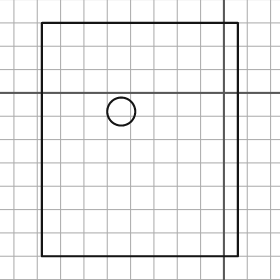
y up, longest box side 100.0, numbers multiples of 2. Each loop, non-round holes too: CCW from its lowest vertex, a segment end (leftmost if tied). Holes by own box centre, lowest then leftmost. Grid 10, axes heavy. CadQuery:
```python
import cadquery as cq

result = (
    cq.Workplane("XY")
    .moveTo(-78.0, -70.0)
    .lineTo(6.0, -70.0)
    .lineTo(6.0, 30.0)
    .lineTo(-78.0, 30.0)
    .close()
    .moveTo(-44.0, -8.0)
    .circle(6.0)
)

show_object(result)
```